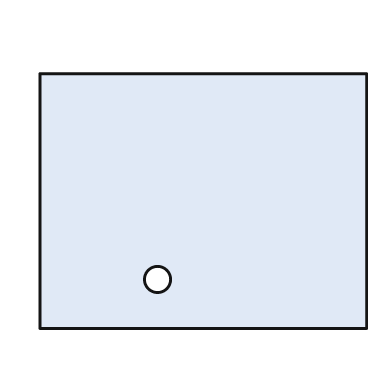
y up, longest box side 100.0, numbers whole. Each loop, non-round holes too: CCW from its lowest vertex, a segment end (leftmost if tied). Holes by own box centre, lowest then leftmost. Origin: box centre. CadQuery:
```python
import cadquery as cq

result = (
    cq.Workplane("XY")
    .moveTo(-50.0, -39.0)
    .lineTo(50.0, -39.0)
    .lineTo(50.0, 39.0)
    .lineTo(-50.0, 39.0)
    .close()
    .moveTo(-14.0, -24.0)
    .circle(4.0)
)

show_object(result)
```